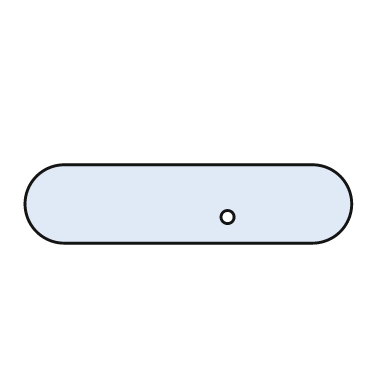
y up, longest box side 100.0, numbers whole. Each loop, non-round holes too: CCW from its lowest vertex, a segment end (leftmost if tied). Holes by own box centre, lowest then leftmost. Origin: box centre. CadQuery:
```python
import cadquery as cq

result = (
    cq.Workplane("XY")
    .moveTo(-38.0, -12.0)
    .lineTo(38.0, -12.0)
    .threePointArc((50.0, 0.0), (38.0, 12.0))
    .lineTo(-38.0, 12.0)
    .threePointArc((-50.0, 0.0), (-38.0, -12.0))
    .close()
    .moveTo(12.0, -4.0)
    .circle(2.0)
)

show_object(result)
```